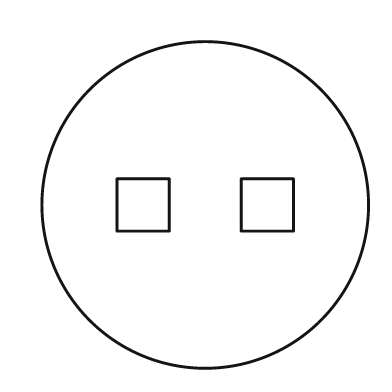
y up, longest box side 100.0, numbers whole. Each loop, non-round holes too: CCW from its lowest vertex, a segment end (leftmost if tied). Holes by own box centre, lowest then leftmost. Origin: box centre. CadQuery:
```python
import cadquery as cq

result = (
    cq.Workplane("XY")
    .moveTo(0.0, 0.0)
    .circle(50.0)
    .moveTo(-27.0, -8.0)
    .lineTo(-11.0, -8.0)
    .lineTo(-11.0, 8.0)
    .lineTo(-27.0, 8.0)
    .close()
    .moveTo(11.0, -8.0)
    .lineTo(27.0, -8.0)
    .lineTo(27.0, 8.0)
    .lineTo(11.0, 8.0)
    .close()
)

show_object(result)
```